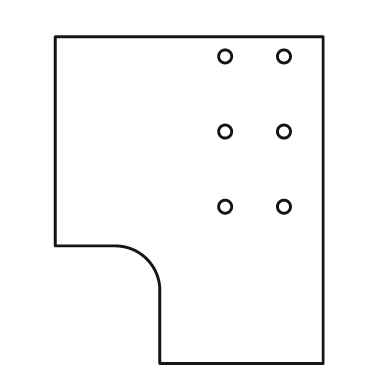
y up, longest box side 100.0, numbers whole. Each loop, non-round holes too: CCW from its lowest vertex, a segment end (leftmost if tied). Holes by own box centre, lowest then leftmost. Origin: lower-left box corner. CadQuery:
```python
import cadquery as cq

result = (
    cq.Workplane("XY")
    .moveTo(32.0, 0.0)
    .lineTo(82.0, 0.0)
    .lineTo(82.0, 100.0)
    .lineTo(0.0, 100.0)
    .lineTo(0.0, 36.0)
    .lineTo(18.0, 36.0)
    .threePointArc((28.0, 32.0), (32.0, 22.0))
    .close()
    .moveTo(52.0, 48.0)
    .circle(2.0)
    .moveTo(70.0, 48.0)
    .circle(2.0)
    .moveTo(52.0, 71.0)
    .circle(2.0)
    .moveTo(70.0, 71.0)
    .circle(2.0)
    .moveTo(52.0, 94.0)
    .circle(2.0)
    .moveTo(70.0, 94.0)
    .circle(2.0)
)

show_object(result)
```